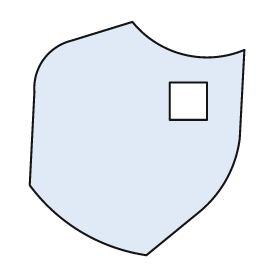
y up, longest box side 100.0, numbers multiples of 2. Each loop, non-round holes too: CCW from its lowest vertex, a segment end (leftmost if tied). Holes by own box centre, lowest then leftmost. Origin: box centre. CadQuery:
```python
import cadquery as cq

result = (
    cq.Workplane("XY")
    .moveTo(4.0, -50.0)
    .lineTo(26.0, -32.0)
    .threePointArc((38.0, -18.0), (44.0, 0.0))
    .lineTo(46.0, 38.0)
    .threePointArc((20.0, 36.0), (-2.0, 50.0))
    .lineTo(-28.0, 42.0)
    .threePointArc((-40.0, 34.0), (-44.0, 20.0))
    .lineTo(-46.0, -20.0)
    .threePointArc((-24.0, -40.0), (4.0, -50.0))
    .close()
    .moveTo(14.0, 8.0)
    .lineTo(30.0, 8.0)
    .lineTo(30.0, 24.0)
    .lineTo(14.0, 24.0)
    .close()
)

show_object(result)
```